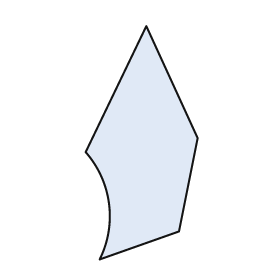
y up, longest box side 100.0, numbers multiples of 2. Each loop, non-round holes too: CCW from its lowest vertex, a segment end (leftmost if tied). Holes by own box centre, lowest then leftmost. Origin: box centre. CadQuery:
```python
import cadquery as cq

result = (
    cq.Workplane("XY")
    .moveTo(-18.0, -50.0)
    .lineTo(16.0, -38.0)
    .lineTo(24.0, 2.0)
    .lineTo(2.0, 50.0)
    .lineTo(-24.0, -4.0)
    .threePointArc((-14.0, -26.0), (-18.0, -50.0))
    .close()
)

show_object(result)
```